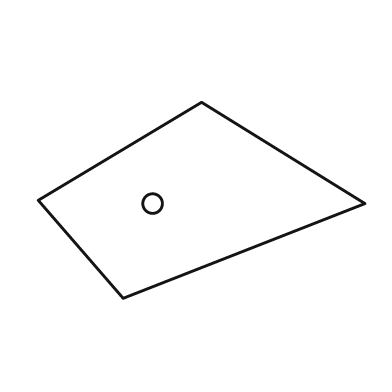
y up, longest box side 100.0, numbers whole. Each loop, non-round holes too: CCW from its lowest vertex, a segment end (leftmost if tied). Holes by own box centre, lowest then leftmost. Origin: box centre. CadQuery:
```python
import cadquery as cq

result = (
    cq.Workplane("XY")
    .moveTo(-24.0, -30.0)
    .lineTo(50.0, -1.0)
    .lineTo(0.0, 30.0)
    .lineTo(-50.0, 0.0)
    .close()
    .moveTo(-15.0, -1.0)
    .circle(3.0)
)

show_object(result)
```